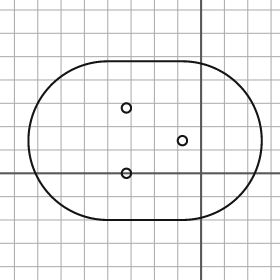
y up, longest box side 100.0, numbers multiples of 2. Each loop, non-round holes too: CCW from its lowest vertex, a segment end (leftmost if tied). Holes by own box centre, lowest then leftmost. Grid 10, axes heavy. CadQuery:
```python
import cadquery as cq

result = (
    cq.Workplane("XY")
    .moveTo(-40.0, -20.0)
    .lineTo(-8.0, -20.0)
    .threePointArc((26.0, 14.0), (-8.0, 48.0))
    .lineTo(-40.0, 48.0)
    .threePointArc((-74.0, 14.0), (-40.0, -20.0))
    .close()
    .moveTo(-32.0, 0.0)
    .circle(2.0)
    .moveTo(-8.0, 14.0)
    .circle(2.0)
    .moveTo(-32.0, 28.0)
    .circle(2.0)
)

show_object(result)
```